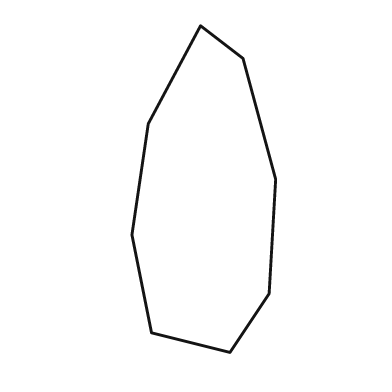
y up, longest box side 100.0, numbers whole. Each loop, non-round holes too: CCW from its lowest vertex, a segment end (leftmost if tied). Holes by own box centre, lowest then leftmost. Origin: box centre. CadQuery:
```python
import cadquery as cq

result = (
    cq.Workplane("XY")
    .moveTo(8.0, -50.0)
    .lineTo(20.0, -32.0)
    .lineTo(22.0, 3.0)
    .lineTo(12.0, 40.0)
    .lineTo(-1.0, 50.0)
    .lineTo(-17.0, 20.0)
    .lineTo(-22.0, -14.0)
    .lineTo(-16.0, -44.0)
    .close()
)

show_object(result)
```